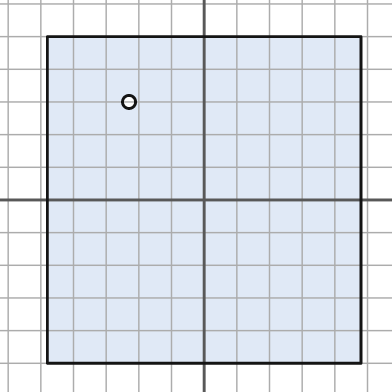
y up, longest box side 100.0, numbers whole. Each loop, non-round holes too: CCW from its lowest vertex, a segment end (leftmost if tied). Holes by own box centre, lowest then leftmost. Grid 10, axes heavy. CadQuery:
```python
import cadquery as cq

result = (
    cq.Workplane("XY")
    .moveTo(-48.0, -50.0)
    .lineTo(48.0, -50.0)
    .lineTo(48.0, 50.0)
    .lineTo(-48.0, 50.0)
    .close()
    .moveTo(-23.0, 30.0)
    .circle(2.0)
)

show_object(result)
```